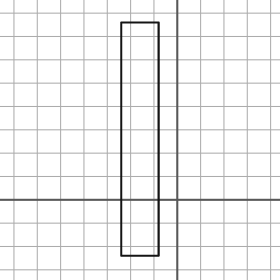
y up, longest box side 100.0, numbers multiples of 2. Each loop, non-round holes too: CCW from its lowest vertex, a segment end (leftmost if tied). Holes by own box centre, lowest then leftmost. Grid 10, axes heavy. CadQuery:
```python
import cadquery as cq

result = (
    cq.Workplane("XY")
    .moveTo(-24.0, -24.0)
    .lineTo(-8.0, -24.0)
    .lineTo(-8.0, 76.0)
    .lineTo(-24.0, 76.0)
    .close()
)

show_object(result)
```